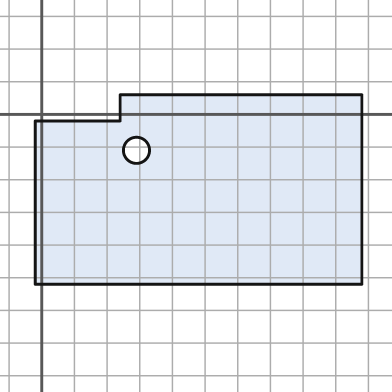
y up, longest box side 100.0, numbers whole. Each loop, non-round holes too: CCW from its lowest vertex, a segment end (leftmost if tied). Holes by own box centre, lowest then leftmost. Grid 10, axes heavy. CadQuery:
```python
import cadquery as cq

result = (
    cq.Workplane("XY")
    .moveTo(-2.0, -52.0)
    .lineTo(98.0, -52.0)
    .lineTo(98.0, 6.0)
    .lineTo(24.0, 6.0)
    .lineTo(24.0, -2.0)
    .lineTo(-2.0, -2.0)
    .close()
    .moveTo(29.0, -11.0)
    .circle(4.0)
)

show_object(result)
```